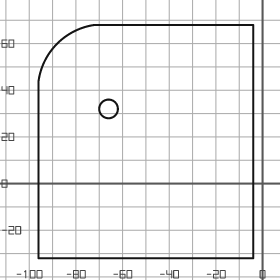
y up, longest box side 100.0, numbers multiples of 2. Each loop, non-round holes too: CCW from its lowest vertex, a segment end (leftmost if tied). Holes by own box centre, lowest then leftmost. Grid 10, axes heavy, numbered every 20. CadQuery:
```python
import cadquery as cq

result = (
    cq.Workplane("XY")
    .moveTo(-96.0, -32.0)
    .lineTo(-4.0, -32.0)
    .lineTo(-4.0, 68.0)
    .lineTo(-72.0, 68.0)
    .threePointArc((-88.0, 60.0), (-96.0, 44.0))
    .close()
    .moveTo(-66.0, 32.0)
    .circle(4.0)
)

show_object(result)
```